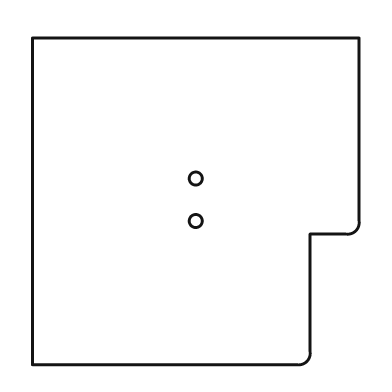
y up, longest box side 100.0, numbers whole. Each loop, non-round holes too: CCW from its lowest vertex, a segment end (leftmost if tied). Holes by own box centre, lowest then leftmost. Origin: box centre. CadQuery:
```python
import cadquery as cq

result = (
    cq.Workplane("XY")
    .moveTo(-50.0, -50.0)
    .lineTo(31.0, -50.0)
    .threePointArc((34.0, -49.0), (35.0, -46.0))
    .lineTo(35.0, -10.0)
    .lineTo(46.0, -10.0)
    .threePointArc((49.0, -9.0), (50.0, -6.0))
    .lineTo(50.0, 50.0)
    .lineTo(-50.0, 50.0)
    .close()
    .moveTo(0.0, -6.0)
    .circle(2.0)
    .moveTo(0.0, 7.0)
    .circle(2.0)
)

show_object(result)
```